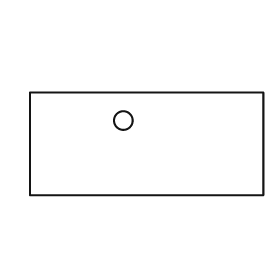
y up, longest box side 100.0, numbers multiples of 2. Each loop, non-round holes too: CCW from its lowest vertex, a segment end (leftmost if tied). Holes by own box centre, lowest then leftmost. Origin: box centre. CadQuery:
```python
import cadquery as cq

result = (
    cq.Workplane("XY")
    .moveTo(-50.0, -22.0)
    .lineTo(50.0, -22.0)
    .lineTo(50.0, 22.0)
    .lineTo(-50.0, 22.0)
    .close()
    .moveTo(-10.0, 10.0)
    .circle(4.0)
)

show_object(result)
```